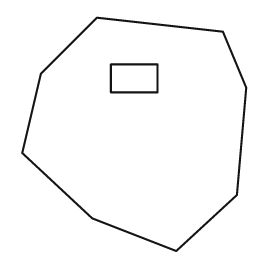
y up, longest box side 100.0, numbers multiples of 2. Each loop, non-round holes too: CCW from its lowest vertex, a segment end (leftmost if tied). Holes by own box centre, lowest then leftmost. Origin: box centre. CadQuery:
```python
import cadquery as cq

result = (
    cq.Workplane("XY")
    .moveTo(18.0, -50.0)
    .lineTo(44.0, -26.0)
    .lineTo(48.0, 20.0)
    .lineTo(38.0, 44.0)
    .lineTo(-16.0, 50.0)
    .lineTo(-40.0, 26.0)
    .lineTo(-48.0, -8.0)
    .lineTo(-18.0, -36.0)
    .close()
    .moveTo(-10.0, 18.0)
    .lineTo(10.0, 18.0)
    .lineTo(10.0, 30.0)
    .lineTo(-10.0, 30.0)
    .close()
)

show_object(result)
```